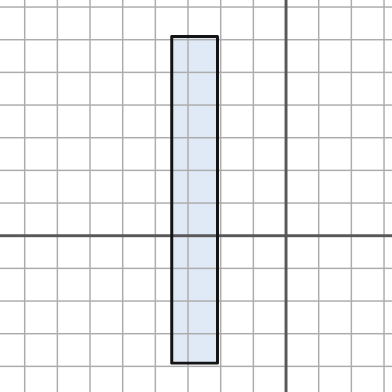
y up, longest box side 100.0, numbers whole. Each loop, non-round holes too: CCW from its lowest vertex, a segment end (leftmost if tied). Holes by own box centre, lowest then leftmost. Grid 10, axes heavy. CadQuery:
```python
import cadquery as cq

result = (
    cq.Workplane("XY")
    .moveTo(-35.0, -39.0)
    .lineTo(-21.0, -39.0)
    .lineTo(-21.0, 61.0)
    .lineTo(-35.0, 61.0)
    .close()
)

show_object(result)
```